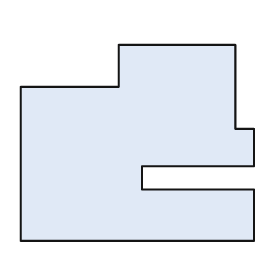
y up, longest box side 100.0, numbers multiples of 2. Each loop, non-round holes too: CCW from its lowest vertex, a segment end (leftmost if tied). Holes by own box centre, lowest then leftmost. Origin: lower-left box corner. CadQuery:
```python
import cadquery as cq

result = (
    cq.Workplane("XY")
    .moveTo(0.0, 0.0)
    .lineTo(100.0, 0.0)
    .lineTo(100.0, 22.0)
    .lineTo(52.0, 22.0)
    .lineTo(52.0, 32.0)
    .lineTo(100.0, 32.0)
    .lineTo(100.0, 48.0)
    .lineTo(92.0, 48.0)
    .lineTo(92.0, 84.0)
    .lineTo(42.0, 84.0)
    .lineTo(42.0, 66.0)
    .lineTo(0.0, 66.0)
    .close()
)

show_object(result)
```